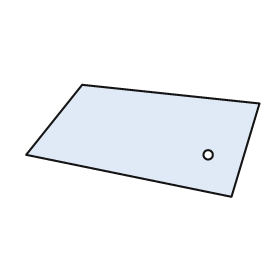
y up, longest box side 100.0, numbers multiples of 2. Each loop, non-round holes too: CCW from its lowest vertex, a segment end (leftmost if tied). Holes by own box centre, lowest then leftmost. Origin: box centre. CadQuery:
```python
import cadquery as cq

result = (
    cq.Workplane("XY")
    .moveTo(38.0, -24.0)
    .lineTo(50.0, 16.0)
    .lineTo(-26.0, 24.0)
    .lineTo(-50.0, -6.0)
    .close()
    .moveTo(28.0, -6.0)
    .circle(2.0)
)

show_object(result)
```